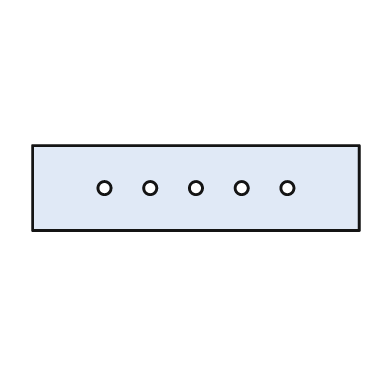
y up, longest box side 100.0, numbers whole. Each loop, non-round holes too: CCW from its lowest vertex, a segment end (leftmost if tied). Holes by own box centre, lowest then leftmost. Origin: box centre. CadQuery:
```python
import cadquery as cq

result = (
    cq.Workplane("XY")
    .moveTo(-50.0, -13.0)
    .lineTo(50.0, -13.0)
    .lineTo(50.0, 13.0)
    .lineTo(-50.0, 13.0)
    .close()
    .moveTo(-28.0, 0.0)
    .circle(2.0)
    .moveTo(-14.0, 0.0)
    .circle(2.0)
    .moveTo(0.0, 0.0)
    .circle(2.0)
    .moveTo(14.0, 0.0)
    .circle(2.0)
    .moveTo(28.0, 0.0)
    .circle(2.0)
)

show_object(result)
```